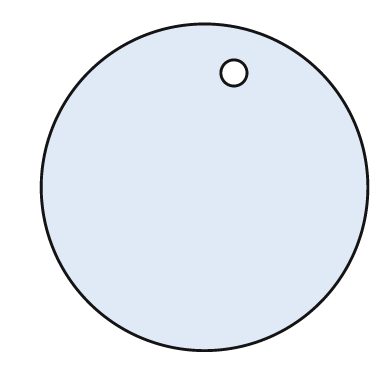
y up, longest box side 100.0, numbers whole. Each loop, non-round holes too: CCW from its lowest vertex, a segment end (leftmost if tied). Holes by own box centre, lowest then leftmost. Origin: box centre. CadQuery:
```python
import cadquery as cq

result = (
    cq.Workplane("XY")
    .moveTo(0.0, 0.0)
    .circle(50.0)
    .moveTo(9.0, 35.0)
    .circle(4.0)
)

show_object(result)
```